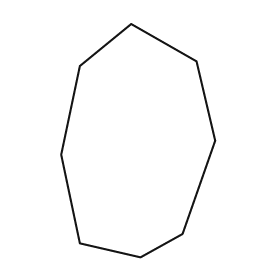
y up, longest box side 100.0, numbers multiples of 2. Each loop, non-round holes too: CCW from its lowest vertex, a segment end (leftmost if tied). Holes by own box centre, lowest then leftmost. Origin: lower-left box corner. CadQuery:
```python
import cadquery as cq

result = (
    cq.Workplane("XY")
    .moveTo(34.0, 0.0)
    .lineTo(52.0, 10.0)
    .lineTo(66.0, 50.0)
    .lineTo(58.0, 84.0)
    .lineTo(30.0, 100.0)
    .lineTo(8.0, 82.0)
    .lineTo(0.0, 44.0)
    .lineTo(8.0, 6.0)
    .close()
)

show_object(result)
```